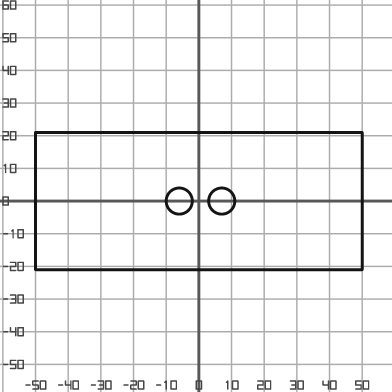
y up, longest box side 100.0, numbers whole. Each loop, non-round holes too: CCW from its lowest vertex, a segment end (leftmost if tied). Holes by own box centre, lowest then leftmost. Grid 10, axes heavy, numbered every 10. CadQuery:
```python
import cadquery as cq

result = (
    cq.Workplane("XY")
    .moveTo(-50.0, -21.0)
    .lineTo(50.0, -21.0)
    .lineTo(50.0, 21.0)
    .lineTo(-50.0, 21.0)
    .close()
    .moveTo(-6.0, 0.0)
    .circle(4.0)
    .moveTo(7.0, 0.0)
    .circle(4.0)
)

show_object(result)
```